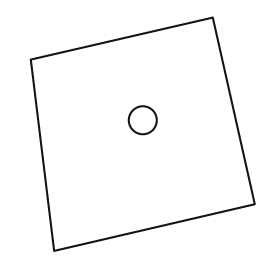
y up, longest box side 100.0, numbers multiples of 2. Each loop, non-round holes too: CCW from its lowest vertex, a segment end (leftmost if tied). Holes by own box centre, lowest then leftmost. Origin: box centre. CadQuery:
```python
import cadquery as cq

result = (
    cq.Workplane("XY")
    .moveTo(-38.0, -50.0)
    .lineTo(48.0, -30.0)
    .lineTo(30.0, 50.0)
    .lineTo(-48.0, 32.0)
    .close()
    .moveTo(0.0, 6.0)
    .circle(6.0)
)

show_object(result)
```